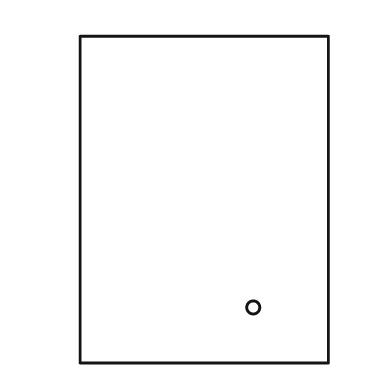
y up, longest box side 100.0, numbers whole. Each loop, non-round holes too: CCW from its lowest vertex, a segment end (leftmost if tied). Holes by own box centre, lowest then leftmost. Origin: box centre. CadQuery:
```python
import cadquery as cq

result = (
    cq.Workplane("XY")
    .moveTo(-38.0, -50.0)
    .lineTo(38.0, -50.0)
    .lineTo(38.0, 50.0)
    .lineTo(-38.0, 50.0)
    .close()
    .moveTo(15.0, -33.0)
    .circle(2.0)
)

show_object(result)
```